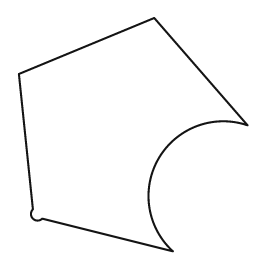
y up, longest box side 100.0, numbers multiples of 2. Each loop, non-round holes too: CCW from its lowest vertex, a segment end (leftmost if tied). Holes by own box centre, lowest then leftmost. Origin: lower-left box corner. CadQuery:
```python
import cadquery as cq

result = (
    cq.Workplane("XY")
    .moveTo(66.0, 0.0)
    .threePointArc((60.0, 40.0), (98.0, 54.0))
    .lineTo(58.0, 100.0)
    .lineTo(0.0, 76.0)
    .lineTo(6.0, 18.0)
    .threePointArc((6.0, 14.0), (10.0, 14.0))
    .close()
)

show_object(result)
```